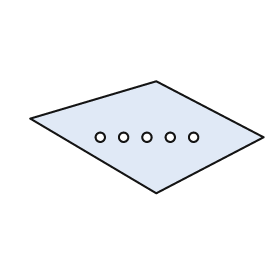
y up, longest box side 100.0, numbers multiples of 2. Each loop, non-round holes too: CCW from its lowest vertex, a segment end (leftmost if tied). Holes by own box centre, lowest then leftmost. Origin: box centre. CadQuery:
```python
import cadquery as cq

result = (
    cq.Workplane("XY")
    .moveTo(4.0, -24.0)
    .lineTo(50.0, 0.0)
    .lineTo(4.0, 24.0)
    .lineTo(-50.0, 8.0)
    .close()
    .moveTo(-20.0, 0.0)
    .circle(2.0)
    .moveTo(-10.0, 0.0)
    .circle(2.0)
    .moveTo(0.0, 0.0)
    .circle(2.0)
    .moveTo(10.0, 0.0)
    .circle(2.0)
    .moveTo(20.0, 0.0)
    .circle(2.0)
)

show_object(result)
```